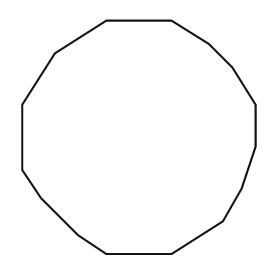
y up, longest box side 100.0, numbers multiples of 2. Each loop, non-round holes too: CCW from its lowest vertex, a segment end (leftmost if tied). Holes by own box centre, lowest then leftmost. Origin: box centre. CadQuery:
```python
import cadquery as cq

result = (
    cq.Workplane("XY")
    .moveTo(-14.0, -50.0)
    .lineTo(14.0, -50.0)
    .lineTo(36.0, -36.0)
    .lineTo(44.0, -22.0)
    .lineTo(50.0, -4.0)
    .lineTo(50.0, 14.0)
    .lineTo(40.0, 30.0)
    .lineTo(30.0, 40.0)
    .lineTo(14.0, 50.0)
    .lineTo(-14.0, 50.0)
    .lineTo(-36.0, 36.0)
    .lineTo(-50.0, 14.0)
    .lineTo(-50.0, -14.0)
    .lineTo(-42.0, -26.0)
    .lineTo(-26.0, -42.0)
    .close()
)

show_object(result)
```